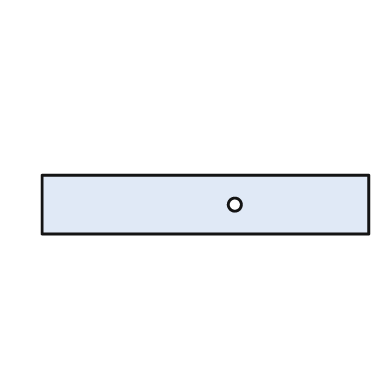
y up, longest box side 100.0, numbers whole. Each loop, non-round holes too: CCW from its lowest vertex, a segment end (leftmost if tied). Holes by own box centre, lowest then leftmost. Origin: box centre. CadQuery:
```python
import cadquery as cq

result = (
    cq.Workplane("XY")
    .moveTo(-50.0, -9.0)
    .lineTo(50.0, -9.0)
    .lineTo(50.0, 9.0)
    .lineTo(-50.0, 9.0)
    .close()
    .moveTo(9.0, 0.0)
    .circle(2.0)
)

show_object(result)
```